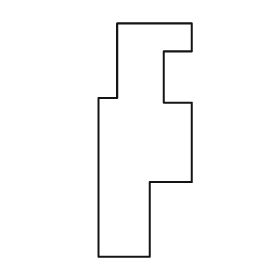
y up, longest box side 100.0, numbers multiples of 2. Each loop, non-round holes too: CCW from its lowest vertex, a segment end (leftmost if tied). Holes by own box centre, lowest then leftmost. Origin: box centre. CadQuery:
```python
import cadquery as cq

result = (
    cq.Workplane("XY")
    .moveTo(-20.0, -50.0)
    .lineTo(2.0, -50.0)
    .lineTo(2.0, -18.0)
    .lineTo(20.0, -18.0)
    .lineTo(20.0, 16.0)
    .lineTo(8.0, 16.0)
    .lineTo(8.0, 38.0)
    .lineTo(20.0, 38.0)
    .lineTo(20.0, 50.0)
    .lineTo(-12.0, 50.0)
    .lineTo(-12.0, 18.0)
    .lineTo(-20.0, 18.0)
    .close()
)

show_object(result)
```